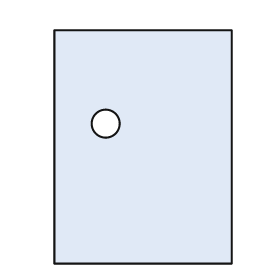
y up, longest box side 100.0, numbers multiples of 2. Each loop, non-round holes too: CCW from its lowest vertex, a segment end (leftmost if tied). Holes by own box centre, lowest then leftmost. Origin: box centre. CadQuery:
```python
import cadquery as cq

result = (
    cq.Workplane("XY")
    .moveTo(-38.0, -50.0)
    .lineTo(38.0, -50.0)
    .lineTo(38.0, 50.0)
    .lineTo(-38.0, 50.0)
    .close()
    .moveTo(-16.0, 10.0)
    .circle(6.0)
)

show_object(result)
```